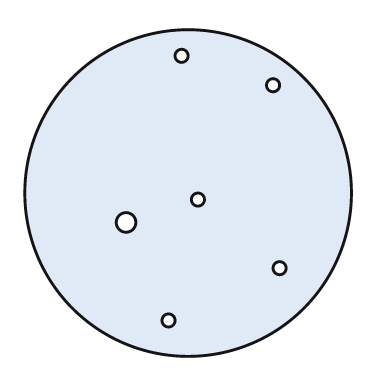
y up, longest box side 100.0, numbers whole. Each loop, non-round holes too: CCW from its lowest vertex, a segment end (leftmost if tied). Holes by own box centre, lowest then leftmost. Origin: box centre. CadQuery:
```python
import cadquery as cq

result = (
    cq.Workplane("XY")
    .moveTo(0.0, 0.0)
    .circle(50.0)
    .moveTo(-6.0, -39.0)
    .circle(2.0)
    .moveTo(28.0, -23.0)
    .circle(2.0)
    .moveTo(-19.0, -9.0)
    .circle(3.0)
    .moveTo(3.0, -2.0)
    .circle(2.0)
    .moveTo(26.0, 33.0)
    .circle(2.0)
    .moveTo(-2.0, 42.0)
    .circle(2.0)
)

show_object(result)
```